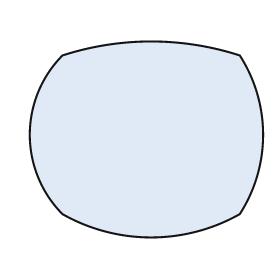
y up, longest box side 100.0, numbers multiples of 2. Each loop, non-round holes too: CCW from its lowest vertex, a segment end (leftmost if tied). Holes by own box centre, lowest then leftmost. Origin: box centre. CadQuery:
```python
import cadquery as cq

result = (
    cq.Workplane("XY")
    .moveTo(-36.0, -32.0)
    .threePointArc((2.0, -42.0), (40.0, -32.0))
    .threePointArc((50.0, 2.0), (40.0, 36.0))
    .threePointArc((2.0, 42.0), (-36.0, 36.0))
    .threePointArc((-50.0, 2.0), (-36.0, -32.0))
    .close()
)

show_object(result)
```